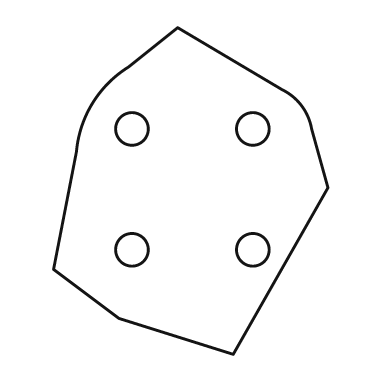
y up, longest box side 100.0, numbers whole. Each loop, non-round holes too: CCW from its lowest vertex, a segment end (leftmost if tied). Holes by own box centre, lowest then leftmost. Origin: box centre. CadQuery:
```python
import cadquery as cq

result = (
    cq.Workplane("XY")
    .moveTo(13.0, -50.0)
    .lineTo(42.0, 1.0)
    .lineTo(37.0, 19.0)
    .threePointArc((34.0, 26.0), (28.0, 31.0))
    .lineTo(-4.0, 50.0)
    .lineTo(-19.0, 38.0)
    .threePointArc((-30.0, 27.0), (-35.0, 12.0))
    .lineTo(-42.0, -24.0)
    .lineTo(-22.0, -39.0)
    .close()
    .moveTo(-18.0, -18.0)
    .circle(5.0)
    .moveTo(19.0, -18.0)
    .circle(5.0)
    .moveTo(-18.0, 19.0)
    .circle(5.0)
    .moveTo(19.0, 19.0)
    .circle(5.0)
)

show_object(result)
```